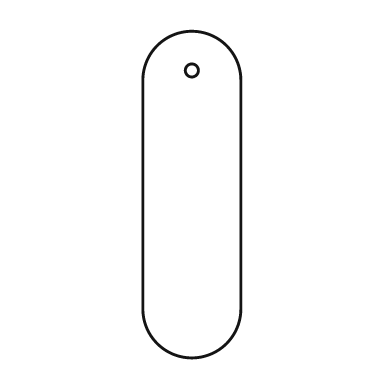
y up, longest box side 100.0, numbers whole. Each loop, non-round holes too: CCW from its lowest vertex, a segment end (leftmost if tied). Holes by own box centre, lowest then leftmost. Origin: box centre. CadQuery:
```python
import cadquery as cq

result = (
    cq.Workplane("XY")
    .moveTo(-15.0, -35.0)
    .threePointArc((0.0, -50.0), (15.0, -35.0))
    .lineTo(15.0, 35.0)
    .threePointArc((0.0, 50.0), (-15.0, 35.0))
    .close()
    .moveTo(0.0, 38.0)
    .circle(2.0)
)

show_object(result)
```